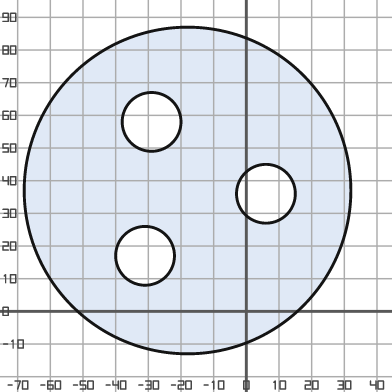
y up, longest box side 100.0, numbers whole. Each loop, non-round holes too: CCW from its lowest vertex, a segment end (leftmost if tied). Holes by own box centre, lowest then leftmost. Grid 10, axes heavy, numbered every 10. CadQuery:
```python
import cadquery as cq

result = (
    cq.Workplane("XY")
    .moveTo(-18.0, 37.0)
    .circle(50.0)
    .moveTo(-31.0, 17.0)
    .circle(9.0)
    .moveTo(6.0, 36.0)
    .circle(9.0)
    .moveTo(-29.0, 58.0)
    .circle(9.0)
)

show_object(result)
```